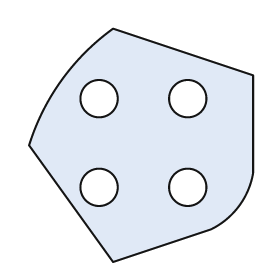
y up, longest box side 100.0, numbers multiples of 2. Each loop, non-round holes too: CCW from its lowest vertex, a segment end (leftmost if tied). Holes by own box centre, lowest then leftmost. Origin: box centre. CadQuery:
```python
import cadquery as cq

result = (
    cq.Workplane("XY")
    .moveTo(-12.0, -50.0)
    .lineTo(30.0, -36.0)
    .threePointArc((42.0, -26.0), (48.0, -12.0))
    .lineTo(48.0, 30.0)
    .lineTo(-12.0, 50.0)
    .threePointArc((-34.0, 28.0), (-48.0, 0.0))
    .close()
    .moveTo(-18.0, -18.0)
    .circle(8.0)
    .moveTo(20.0, -18.0)
    .circle(8.0)
    .moveTo(-18.0, 20.0)
    .circle(8.0)
    .moveTo(20.0, 20.0)
    .circle(8.0)
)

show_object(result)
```